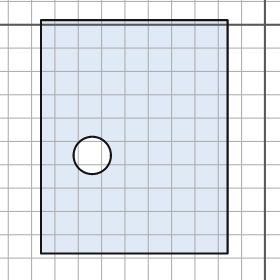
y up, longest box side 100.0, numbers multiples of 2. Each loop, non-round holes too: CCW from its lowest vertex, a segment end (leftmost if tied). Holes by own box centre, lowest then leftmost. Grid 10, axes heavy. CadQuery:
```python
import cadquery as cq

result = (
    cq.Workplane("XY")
    .moveTo(-96.0, -98.0)
    .lineTo(-16.0, -98.0)
    .lineTo(-16.0, 2.0)
    .lineTo(-96.0, 2.0)
    .close()
    .moveTo(-74.0, -56.0)
    .circle(8.0)
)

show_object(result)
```